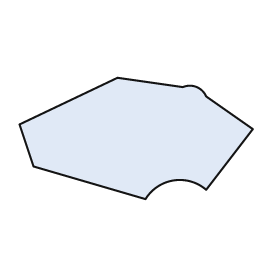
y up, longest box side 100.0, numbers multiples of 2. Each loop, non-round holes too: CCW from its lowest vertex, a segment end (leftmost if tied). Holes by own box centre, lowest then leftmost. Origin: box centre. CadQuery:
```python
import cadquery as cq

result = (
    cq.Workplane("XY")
    .moveTo(4.0, -26.0)
    .threePointArc((16.0, -18.0), (30.0, -22.0))
    .lineTo(50.0, 4.0)
    .lineTo(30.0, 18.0)
    .threePointArc((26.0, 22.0), (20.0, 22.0))
    .lineTo(-8.0, 26.0)
    .lineTo(-50.0, 6.0)
    .lineTo(-44.0, -12.0)
    .close()
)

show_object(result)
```